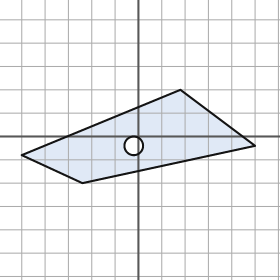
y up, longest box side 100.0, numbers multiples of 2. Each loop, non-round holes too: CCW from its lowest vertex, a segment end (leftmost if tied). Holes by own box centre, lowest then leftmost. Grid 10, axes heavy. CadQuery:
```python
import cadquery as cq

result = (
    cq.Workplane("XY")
    .moveTo(-24.0, -20.0)
    .lineTo(50.0, -4.0)
    .lineTo(18.0, 20.0)
    .lineTo(-50.0, -8.0)
    .close()
    .moveTo(-2.0, -4.0)
    .circle(4.0)
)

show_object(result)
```